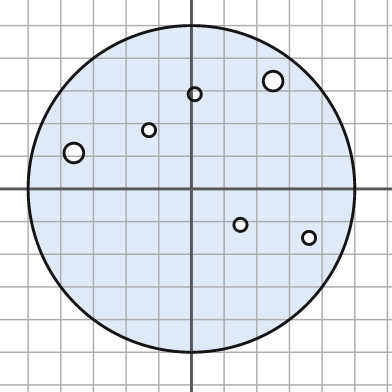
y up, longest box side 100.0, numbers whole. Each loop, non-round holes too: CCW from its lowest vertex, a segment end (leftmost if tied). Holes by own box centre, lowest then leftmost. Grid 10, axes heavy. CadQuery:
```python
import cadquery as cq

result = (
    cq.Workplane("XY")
    .moveTo(0.0, 0.0)
    .circle(50.0)
    .moveTo(36.0, -15.0)
    .circle(2.0)
    .moveTo(15.0, -11.0)
    .circle(2.0)
    .moveTo(-36.0, 11.0)
    .circle(3.0)
    .moveTo(-13.0, 18.0)
    .circle(2.0)
    .moveTo(1.0, 29.0)
    .circle(2.0)
    .moveTo(25.0, 33.0)
    .circle(3.0)
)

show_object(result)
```